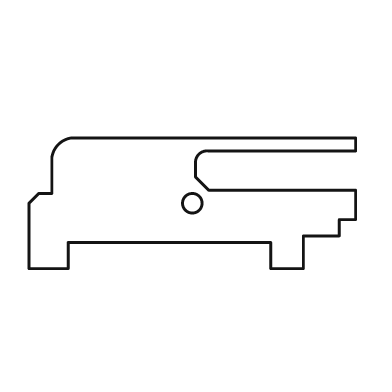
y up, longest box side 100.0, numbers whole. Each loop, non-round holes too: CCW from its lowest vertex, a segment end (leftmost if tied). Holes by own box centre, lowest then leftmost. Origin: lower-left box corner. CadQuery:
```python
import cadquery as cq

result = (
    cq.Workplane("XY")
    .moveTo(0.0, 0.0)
    .lineTo(12.0, 0.0)
    .lineTo(12.0, 8.0)
    .lineTo(74.0, 8.0)
    .lineTo(74.0, 0.0)
    .lineTo(84.0, 0.0)
    .lineTo(84.0, 10.0)
    .lineTo(95.0, 10.0)
    .lineTo(95.0, 15.0)
    .lineTo(100.0, 15.0)
    .lineTo(100.0, 24.0)
    .lineTo(55.0, 24.0)
    .lineTo(51.0, 28.0)
    .lineTo(51.0, 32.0)
    .threePointArc((52.0, 35.0), (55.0, 36.0))
    .lineTo(100.0, 36.0)
    .lineTo(100.0, 40.0)
    .lineTo(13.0, 40.0)
    .threePointArc((9.0, 38.0), (7.0, 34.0))
    .lineTo(7.0, 23.0)
    .lineTo(3.0, 23.0)
    .lineTo(0.0, 20.0)
    .close()
    .moveTo(50.0, 20.0)
    .circle(3.0)
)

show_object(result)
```